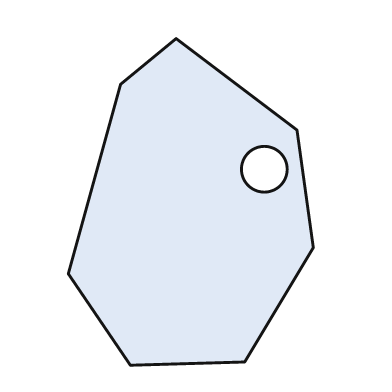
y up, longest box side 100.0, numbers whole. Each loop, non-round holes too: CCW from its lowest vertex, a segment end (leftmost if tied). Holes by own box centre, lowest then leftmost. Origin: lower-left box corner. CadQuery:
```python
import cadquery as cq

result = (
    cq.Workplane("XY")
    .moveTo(19.0, 0.0)
    .lineTo(54.0, 1.0)
    .lineTo(75.0, 36.0)
    .lineTo(70.0, 72.0)
    .lineTo(33.0, 100.0)
    .lineTo(16.0, 86.0)
    .lineTo(0.0, 28.0)
    .close()
    .moveTo(60.0, 60.0)
    .circle(7.0)
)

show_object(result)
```